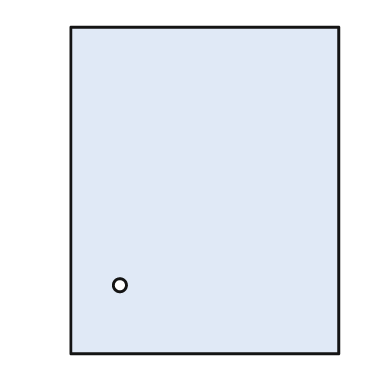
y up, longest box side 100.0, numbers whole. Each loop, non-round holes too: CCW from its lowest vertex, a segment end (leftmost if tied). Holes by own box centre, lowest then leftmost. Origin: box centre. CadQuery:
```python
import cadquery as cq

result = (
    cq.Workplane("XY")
    .moveTo(-41.0, -50.0)
    .lineTo(41.0, -50.0)
    .lineTo(41.0, 50.0)
    .lineTo(-41.0, 50.0)
    .close()
    .moveTo(-26.0, -29.0)
    .circle(2.0)
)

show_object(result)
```